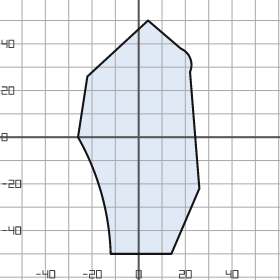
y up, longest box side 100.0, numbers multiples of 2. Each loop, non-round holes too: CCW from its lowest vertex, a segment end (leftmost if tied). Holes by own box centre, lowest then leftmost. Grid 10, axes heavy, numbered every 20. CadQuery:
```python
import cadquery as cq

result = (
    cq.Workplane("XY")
    .moveTo(-12.0, -50.0)
    .lineTo(14.0, -50.0)
    .lineTo(26.0, -22.0)
    .lineTo(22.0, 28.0)
    .threePointArc((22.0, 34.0), (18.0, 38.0))
    .lineTo(4.0, 50.0)
    .lineTo(-22.0, 26.0)
    .lineTo(-26.0, 0.0)
    .threePointArc((-16.0, -24.0), (-12.0, -50.0))
    .close()
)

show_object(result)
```